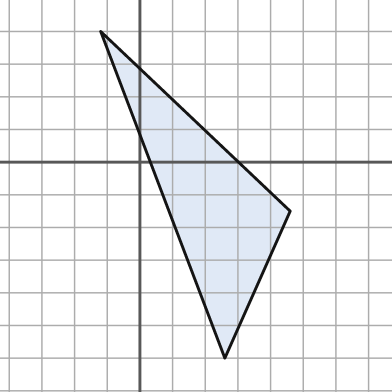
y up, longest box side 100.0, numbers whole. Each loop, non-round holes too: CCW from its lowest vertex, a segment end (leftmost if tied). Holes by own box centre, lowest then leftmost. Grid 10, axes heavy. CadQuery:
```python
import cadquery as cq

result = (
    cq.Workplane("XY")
    .moveTo(26.0, -60.0)
    .lineTo(46.0, -15.0)
    .lineTo(-12.0, 40.0)
    .close()
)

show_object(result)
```